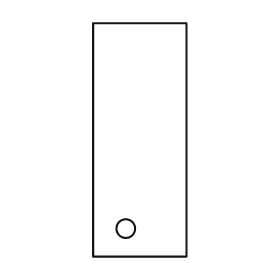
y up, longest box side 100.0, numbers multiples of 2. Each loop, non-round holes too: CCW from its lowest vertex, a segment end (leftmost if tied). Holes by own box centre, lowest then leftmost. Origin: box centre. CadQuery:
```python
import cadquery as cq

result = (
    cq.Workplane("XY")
    .moveTo(-20.0, -50.0)
    .lineTo(20.0, -50.0)
    .lineTo(20.0, 50.0)
    .lineTo(-20.0, 50.0)
    .close()
    .moveTo(-6.0, -38.0)
    .circle(4.0)
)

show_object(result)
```